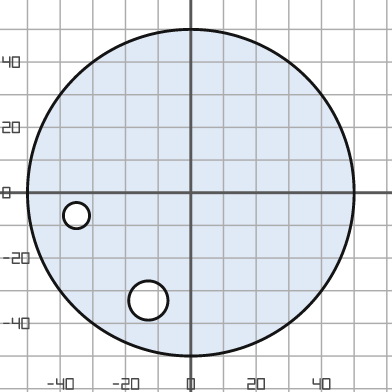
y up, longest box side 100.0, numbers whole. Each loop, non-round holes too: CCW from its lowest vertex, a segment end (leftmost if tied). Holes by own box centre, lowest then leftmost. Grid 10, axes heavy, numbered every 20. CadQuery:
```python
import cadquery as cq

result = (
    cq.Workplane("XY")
    .moveTo(0.0, 0.0)
    .circle(50.0)
    .moveTo(-13.0, -33.0)
    .circle(6.0)
    .moveTo(-35.0, -7.0)
    .circle(4.0)
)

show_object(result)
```